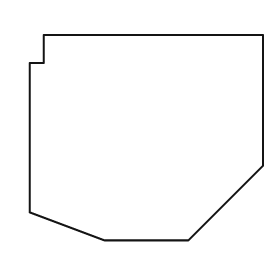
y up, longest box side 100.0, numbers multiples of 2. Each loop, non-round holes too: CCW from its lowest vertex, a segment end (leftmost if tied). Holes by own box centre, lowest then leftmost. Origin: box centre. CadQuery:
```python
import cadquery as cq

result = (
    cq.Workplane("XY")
    .moveTo(-18.0, -44.0)
    .lineTo(18.0, -44.0)
    .lineTo(50.0, -12.0)
    .lineTo(50.0, 44.0)
    .lineTo(-44.0, 44.0)
    .lineTo(-44.0, 32.0)
    .lineTo(-50.0, 32.0)
    .lineTo(-50.0, -32.0)
    .close()
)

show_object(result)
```